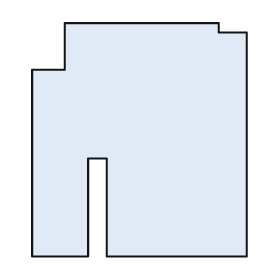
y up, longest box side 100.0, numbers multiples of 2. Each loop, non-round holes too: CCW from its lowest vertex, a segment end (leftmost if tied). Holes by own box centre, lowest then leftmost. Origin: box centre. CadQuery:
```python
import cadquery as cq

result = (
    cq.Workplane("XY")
    .moveTo(-46.0, -50.0)
    .lineTo(-22.0, -50.0)
    .lineTo(-22.0, -8.0)
    .lineTo(-14.0, -8.0)
    .lineTo(-14.0, -50.0)
    .lineTo(46.0, -50.0)
    .lineTo(46.0, 46.0)
    .lineTo(34.0, 46.0)
    .lineTo(34.0, 50.0)
    .lineTo(-32.0, 50.0)
    .lineTo(-32.0, 30.0)
    .lineTo(-46.0, 30.0)
    .close()
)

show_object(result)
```